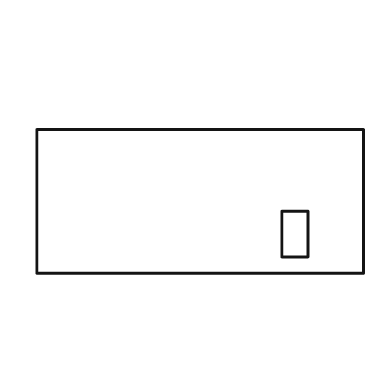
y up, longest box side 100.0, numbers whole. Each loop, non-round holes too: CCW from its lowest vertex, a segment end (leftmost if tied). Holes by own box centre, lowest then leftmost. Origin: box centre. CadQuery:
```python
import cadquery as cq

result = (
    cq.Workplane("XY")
    .moveTo(-50.0, -22.0)
    .lineTo(50.0, -22.0)
    .lineTo(50.0, 22.0)
    .lineTo(-50.0, 22.0)
    .close()
    .moveTo(25.0, -17.0)
    .lineTo(33.0, -17.0)
    .lineTo(33.0, -3.0)
    .lineTo(25.0, -3.0)
    .close()
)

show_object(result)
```